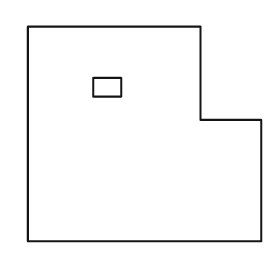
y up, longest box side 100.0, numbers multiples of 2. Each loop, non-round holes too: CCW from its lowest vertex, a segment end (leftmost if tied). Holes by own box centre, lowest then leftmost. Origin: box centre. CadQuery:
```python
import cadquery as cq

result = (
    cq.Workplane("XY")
    .moveTo(-50.0, -46.0)
    .lineTo(50.0, -46.0)
    .lineTo(50.0, 6.0)
    .lineTo(24.0, 6.0)
    .lineTo(24.0, 46.0)
    .lineTo(-50.0, 46.0)
    .close()
    .moveTo(-22.0, 16.0)
    .lineTo(-10.0, 16.0)
    .lineTo(-10.0, 24.0)
    .lineTo(-22.0, 24.0)
    .close()
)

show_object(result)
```